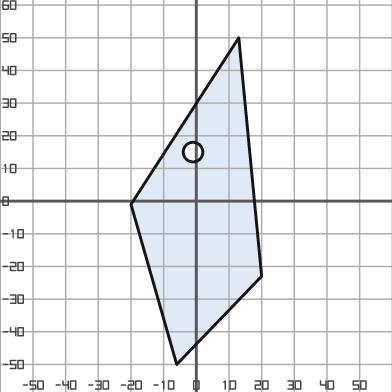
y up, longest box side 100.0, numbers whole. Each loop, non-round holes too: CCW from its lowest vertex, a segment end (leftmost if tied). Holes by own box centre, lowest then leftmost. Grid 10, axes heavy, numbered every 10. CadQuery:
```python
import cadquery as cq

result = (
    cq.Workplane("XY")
    .moveTo(-6.0, -50.0)
    .lineTo(20.0, -23.0)
    .lineTo(13.0, 50.0)
    .lineTo(-20.0, -1.0)
    .close()
    .moveTo(-1.0, 15.0)
    .circle(3.0)
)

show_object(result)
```